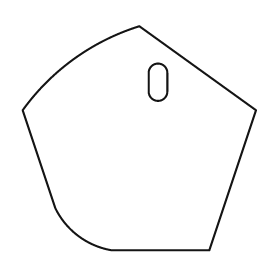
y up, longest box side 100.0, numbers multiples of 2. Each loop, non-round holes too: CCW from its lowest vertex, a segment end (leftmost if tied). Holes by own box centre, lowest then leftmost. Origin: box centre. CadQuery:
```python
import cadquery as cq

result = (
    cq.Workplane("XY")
    .moveTo(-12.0, -48.0)
    .lineTo(30.0, -48.0)
    .lineTo(50.0, 12.0)
    .lineTo(0.0, 48.0)
    .threePointArc((-28.0, 34.0), (-50.0, 12.0))
    .lineTo(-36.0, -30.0)
    .threePointArc((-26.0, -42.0), (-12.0, -48.0))
    .close()
    .moveTo(4.0, 20.0)
    .threePointArc((8.0, 16.0), (12.0, 20.0))
    .lineTo(12.0, 28.0)
    .threePointArc((8.0, 32.0), (4.0, 28.0))
    .close()
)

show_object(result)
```